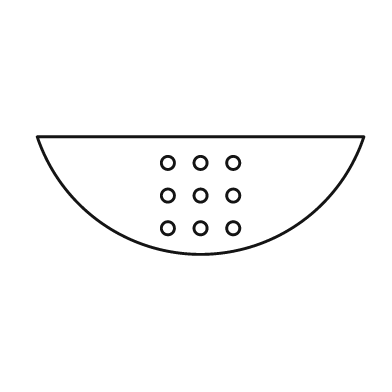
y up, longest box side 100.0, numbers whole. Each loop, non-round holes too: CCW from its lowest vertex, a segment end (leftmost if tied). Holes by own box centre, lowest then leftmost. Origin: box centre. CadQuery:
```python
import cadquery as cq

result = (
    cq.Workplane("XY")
    .moveTo(-50.0, 18.0)
    .threePointArc((0.0, -18.0), (50.0, 18.0))
    .close()
    .moveTo(-10.0, -10.0)
    .circle(2.0)
    .moveTo(0.0, -10.0)
    .circle(2.0)
    .moveTo(10.0, -10.0)
    .circle(2.0)
    .moveTo(-10.0, 0.0)
    .circle(2.0)
    .moveTo(0.0, 0.0)
    .circle(2.0)
    .moveTo(10.0, 0.0)
    .circle(2.0)
    .moveTo(-10.0, 10.0)
    .circle(2.0)
    .moveTo(0.0, 10.0)
    .circle(2.0)
    .moveTo(10.0, 10.0)
    .circle(2.0)
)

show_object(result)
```